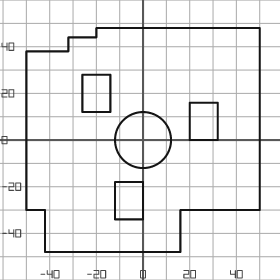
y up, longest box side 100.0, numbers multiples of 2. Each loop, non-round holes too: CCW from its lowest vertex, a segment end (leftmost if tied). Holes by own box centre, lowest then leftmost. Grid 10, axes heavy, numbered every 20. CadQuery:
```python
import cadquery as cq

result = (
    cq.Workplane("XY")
    .moveTo(-42.0, -48.0)
    .lineTo(16.0, -48.0)
    .lineTo(16.0, -30.0)
    .lineTo(50.0, -30.0)
    .lineTo(50.0, 48.0)
    .lineTo(-20.0, 48.0)
    .lineTo(-20.0, 44.0)
    .lineTo(-32.0, 44.0)
    .lineTo(-32.0, 38.0)
    .lineTo(-50.0, 38.0)
    .lineTo(-50.0, -30.0)
    .lineTo(-42.0, -30.0)
    .close()
    .moveTo(-12.0, -34.0)
    .lineTo(0.0, -34.0)
    .lineTo(0.0, -18.0)
    .lineTo(-12.0, -18.0)
    .close()
    .moveTo(0.0, 0.0)
    .circle(12.0)
    .moveTo(20.0, 0.0)
    .lineTo(32.0, 0.0)
    .lineTo(32.0, 16.0)
    .lineTo(20.0, 16.0)
    .close()
    .moveTo(-26.0, 12.0)
    .lineTo(-14.0, 12.0)
    .lineTo(-14.0, 28.0)
    .lineTo(-26.0, 28.0)
    .close()
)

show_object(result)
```